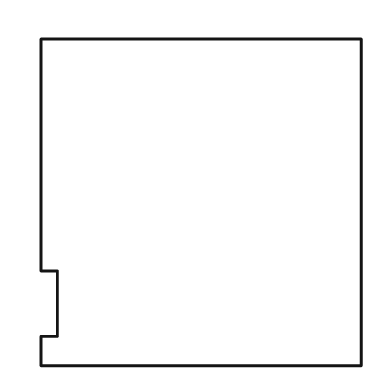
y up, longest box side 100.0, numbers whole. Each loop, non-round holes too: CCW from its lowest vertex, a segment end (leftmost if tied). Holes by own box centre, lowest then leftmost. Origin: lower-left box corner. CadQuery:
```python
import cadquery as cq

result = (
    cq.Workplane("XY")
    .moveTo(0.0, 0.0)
    .lineTo(98.0, 0.0)
    .lineTo(98.0, 100.0)
    .lineTo(0.0, 100.0)
    .lineTo(0.0, 29.0)
    .lineTo(5.0, 29.0)
    .lineTo(5.0, 9.0)
    .lineTo(0.0, 9.0)
    .close()
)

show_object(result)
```